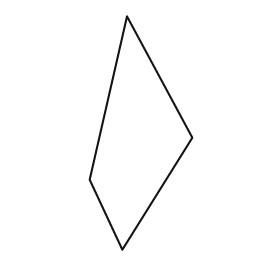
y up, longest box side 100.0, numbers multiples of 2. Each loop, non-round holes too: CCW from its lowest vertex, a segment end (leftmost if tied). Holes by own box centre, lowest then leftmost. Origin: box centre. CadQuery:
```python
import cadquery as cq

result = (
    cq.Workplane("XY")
    .moveTo(-8.0, -50.0)
    .lineTo(22.0, -2.0)
    .lineTo(-6.0, 50.0)
    .lineTo(-22.0, -20.0)
    .close()
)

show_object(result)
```